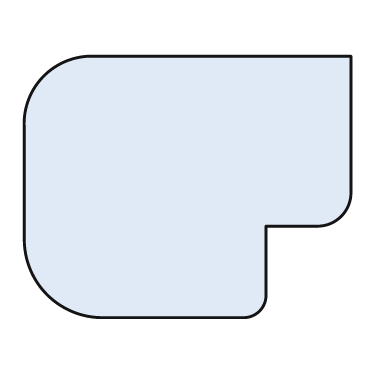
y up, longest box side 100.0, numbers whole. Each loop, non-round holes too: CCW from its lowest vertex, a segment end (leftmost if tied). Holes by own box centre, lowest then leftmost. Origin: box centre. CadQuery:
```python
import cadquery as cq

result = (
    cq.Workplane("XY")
    .moveTo(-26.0, -40.0)
    .lineTo(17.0, -40.0)
    .threePointArc((22.0, -38.0), (24.0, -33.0))
    .lineTo(24.0, -12.0)
    .lineTo(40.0, -12.0)
    .threePointArc((47.0, -9.0), (50.0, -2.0))
    .lineTo(50.0, 40.0)
    .lineTo(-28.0, 40.0)
    .threePointArc((-44.0, 34.0), (-50.0, 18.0))
    .lineTo(-50.0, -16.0)
    .threePointArc((-43.0, -33.0), (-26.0, -40.0))
    .close()
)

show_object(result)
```